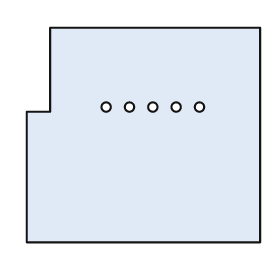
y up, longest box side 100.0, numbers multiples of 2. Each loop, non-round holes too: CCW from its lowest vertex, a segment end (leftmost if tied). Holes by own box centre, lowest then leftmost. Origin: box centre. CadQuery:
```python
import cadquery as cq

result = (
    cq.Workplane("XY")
    .moveTo(-50.0, -46.0)
    .lineTo(50.0, -46.0)
    .lineTo(50.0, 46.0)
    .lineTo(-40.0, 46.0)
    .lineTo(-40.0, 10.0)
    .lineTo(-50.0, 10.0)
    .close()
    .moveTo(-16.0, 12.0)
    .circle(2.0)
    .moveTo(-6.0, 12.0)
    .circle(2.0)
    .moveTo(4.0, 12.0)
    .circle(2.0)
    .moveTo(14.0, 12.0)
    .circle(2.0)
    .moveTo(24.0, 12.0)
    .circle(2.0)
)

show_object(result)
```